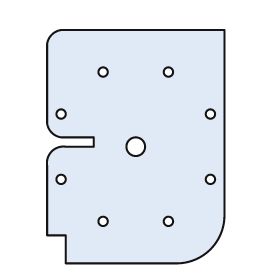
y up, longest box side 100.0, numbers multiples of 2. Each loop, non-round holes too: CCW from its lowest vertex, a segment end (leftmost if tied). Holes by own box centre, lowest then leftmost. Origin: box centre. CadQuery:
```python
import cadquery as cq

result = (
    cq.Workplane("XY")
    .moveTo(-30.0, -50.0)
    .lineTo(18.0, -50.0)
    .threePointArc((32.0, -44.0), (38.0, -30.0))
    .lineTo(38.0, 50.0)
    .lineTo(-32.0, 50.0)
    .threePointArc((-36.0, 48.0), (-38.0, 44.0))
    .lineTo(-38.0, 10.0)
    .threePointArc((-36.0, 6.0), (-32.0, 4.0))
    .lineTo(-18.0, 4.0)
    .lineTo(-18.0, 0.0)
    .lineTo(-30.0, 0.0)
    .threePointArc((-36.0, -2.0), (-38.0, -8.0))
    .lineTo(-38.0, -38.0)
    .lineTo(-30.0, -38.0)
    .close()
    .moveTo(-14.0, -32.0)
    .circle(2.0)
    .moveTo(14.0, -32.0)
    .circle(2.0)
    .moveTo(-32.0, -14.0)
    .circle(2.0)
    .moveTo(32.0, -14.0)
    .circle(2.0)
    .moveTo(0.0, 0.0)
    .circle(4.0)
    .moveTo(-32.0, 14.0)
    .circle(2.0)
    .moveTo(32.0, 14.0)
    .circle(2.0)
    .moveTo(-14.0, 32.0)
    .circle(2.0)
    .moveTo(14.0, 32.0)
    .circle(2.0)
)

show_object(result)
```